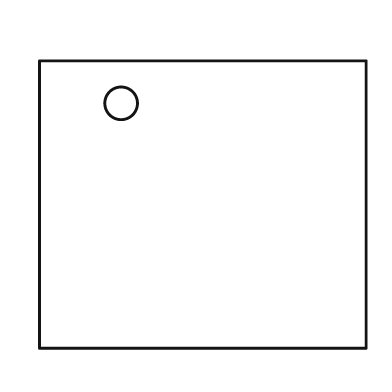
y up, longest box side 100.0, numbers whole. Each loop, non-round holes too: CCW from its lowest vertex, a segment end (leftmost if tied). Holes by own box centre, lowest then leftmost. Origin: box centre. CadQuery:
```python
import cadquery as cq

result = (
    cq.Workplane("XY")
    .moveTo(-50.0, -44.0)
    .lineTo(50.0, -44.0)
    .lineTo(50.0, 44.0)
    .lineTo(-50.0, 44.0)
    .close()
    .moveTo(-25.0, 31.0)
    .circle(5.0)
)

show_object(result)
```